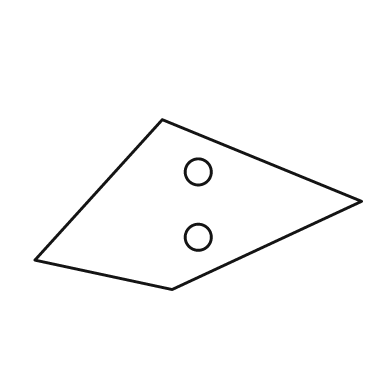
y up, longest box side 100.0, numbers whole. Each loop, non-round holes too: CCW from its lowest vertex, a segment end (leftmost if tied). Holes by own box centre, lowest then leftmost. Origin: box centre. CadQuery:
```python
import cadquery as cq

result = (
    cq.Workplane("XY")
    .moveTo(-8.0, -26.0)
    .lineTo(50.0, 1.0)
    .lineTo(-11.0, 26.0)
    .lineTo(-50.0, -17.0)
    .close()
    .moveTo(0.0, -10.0)
    .circle(4.0)
    .moveTo(0.0, 10.0)
    .circle(4.0)
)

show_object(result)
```